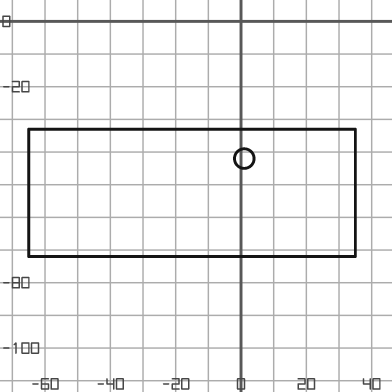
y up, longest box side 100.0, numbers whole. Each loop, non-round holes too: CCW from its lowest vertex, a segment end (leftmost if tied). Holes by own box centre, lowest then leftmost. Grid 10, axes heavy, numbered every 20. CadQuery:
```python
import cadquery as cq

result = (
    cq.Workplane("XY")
    .moveTo(-65.0, -72.0)
    .lineTo(35.0, -72.0)
    .lineTo(35.0, -33.0)
    .lineTo(-65.0, -33.0)
    .close()
    .moveTo(1.0, -42.0)
    .circle(3.0)
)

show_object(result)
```